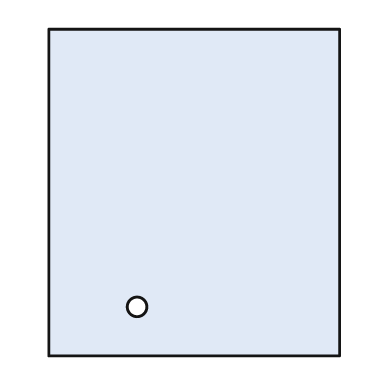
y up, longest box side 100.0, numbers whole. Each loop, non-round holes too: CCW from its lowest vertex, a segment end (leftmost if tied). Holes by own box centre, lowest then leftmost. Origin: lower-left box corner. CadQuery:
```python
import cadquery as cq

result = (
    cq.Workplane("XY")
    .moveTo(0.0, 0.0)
    .lineTo(89.0, 0.0)
    .lineTo(89.0, 100.0)
    .lineTo(0.0, 100.0)
    .close()
    .moveTo(27.0, 15.0)
    .circle(3.0)
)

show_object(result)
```